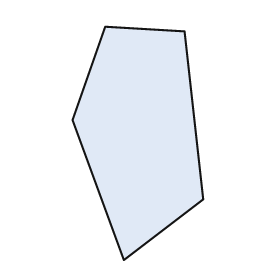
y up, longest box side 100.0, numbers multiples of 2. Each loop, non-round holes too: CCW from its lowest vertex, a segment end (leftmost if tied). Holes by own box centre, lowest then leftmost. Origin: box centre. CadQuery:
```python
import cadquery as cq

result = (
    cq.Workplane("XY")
    .moveTo(-6.0, -50.0)
    .lineTo(28.0, -24.0)
    .lineTo(20.0, 48.0)
    .lineTo(-14.0, 50.0)
    .lineTo(-28.0, 10.0)
    .close()
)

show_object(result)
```